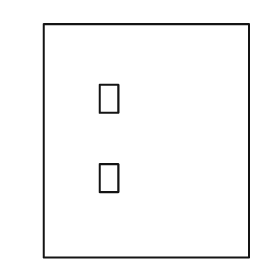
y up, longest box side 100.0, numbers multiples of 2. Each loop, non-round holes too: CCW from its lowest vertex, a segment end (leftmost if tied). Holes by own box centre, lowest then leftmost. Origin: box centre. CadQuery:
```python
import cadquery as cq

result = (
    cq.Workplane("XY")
    .moveTo(-44.0, -50.0)
    .lineTo(44.0, -50.0)
    .lineTo(44.0, 50.0)
    .lineTo(-44.0, 50.0)
    .close()
    .moveTo(-20.0, -22.0)
    .lineTo(-12.0, -22.0)
    .lineTo(-12.0, -10.0)
    .lineTo(-20.0, -10.0)
    .close()
    .moveTo(-20.0, 12.0)
    .lineTo(-12.0, 12.0)
    .lineTo(-12.0, 24.0)
    .lineTo(-20.0, 24.0)
    .close()
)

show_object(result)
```